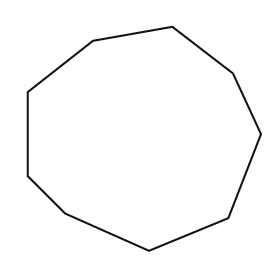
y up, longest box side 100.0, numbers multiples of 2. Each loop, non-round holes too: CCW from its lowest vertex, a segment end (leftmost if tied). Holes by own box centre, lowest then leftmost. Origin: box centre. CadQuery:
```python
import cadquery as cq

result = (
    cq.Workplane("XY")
    .moveTo(2.0, -48.0)
    .lineTo(36.0, -34.0)
    .lineTo(50.0, 2.0)
    .lineTo(38.0, 28.0)
    .lineTo(12.0, 48.0)
    .lineTo(-22.0, 42.0)
    .lineTo(-50.0, 20.0)
    .lineTo(-50.0, -16.0)
    .lineTo(-34.0, -32.0)
    .close()
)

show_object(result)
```